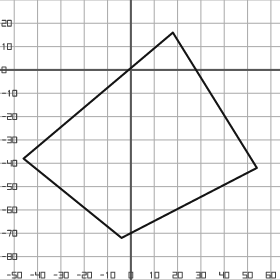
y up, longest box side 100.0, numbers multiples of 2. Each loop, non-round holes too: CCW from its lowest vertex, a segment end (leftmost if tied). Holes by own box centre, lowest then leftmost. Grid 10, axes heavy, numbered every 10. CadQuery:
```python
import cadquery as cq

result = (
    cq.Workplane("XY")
    .moveTo(-4.0, -72.0)
    .lineTo(54.0, -42.0)
    .lineTo(18.0, 16.0)
    .lineTo(-46.0, -38.0)
    .close()
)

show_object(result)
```